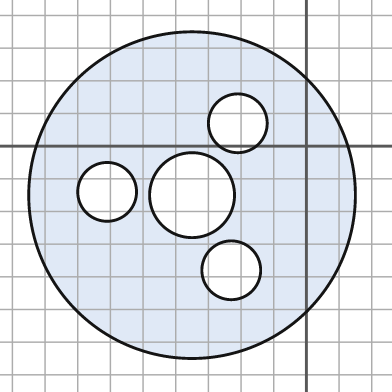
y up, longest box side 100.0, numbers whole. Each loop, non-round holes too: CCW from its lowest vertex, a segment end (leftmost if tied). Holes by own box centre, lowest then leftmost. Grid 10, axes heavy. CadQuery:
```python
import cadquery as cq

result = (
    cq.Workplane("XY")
    .moveTo(-35.0, -15.0)
    .circle(50.0)
    .moveTo(-23.0, -38.0)
    .circle(9.0)
    .moveTo(-35.0, -15.0)
    .circle(13.0)
    .moveTo(-61.0, -14.0)
    .circle(9.0)
    .moveTo(-21.0, 7.0)
    .circle(9.0)
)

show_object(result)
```